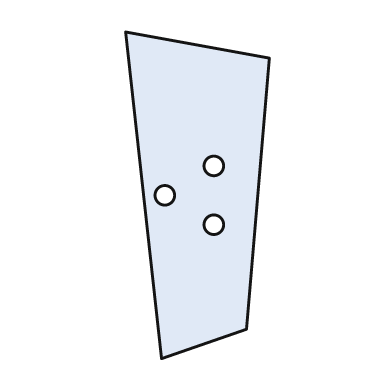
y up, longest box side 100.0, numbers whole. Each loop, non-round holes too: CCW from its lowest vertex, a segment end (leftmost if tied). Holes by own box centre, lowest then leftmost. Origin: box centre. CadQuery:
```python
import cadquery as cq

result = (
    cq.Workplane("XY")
    .moveTo(-11.0, -50.0)
    .lineTo(15.0, -41.0)
    .lineTo(22.0, 42.0)
    .lineTo(-22.0, 50.0)
    .close()
    .moveTo(5.0, -9.0)
    .circle(3.0)
    .moveTo(-10.0, 0.0)
    .circle(3.0)
    .moveTo(5.0, 9.0)
    .circle(3.0)
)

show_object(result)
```